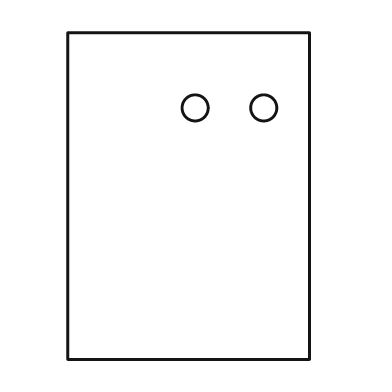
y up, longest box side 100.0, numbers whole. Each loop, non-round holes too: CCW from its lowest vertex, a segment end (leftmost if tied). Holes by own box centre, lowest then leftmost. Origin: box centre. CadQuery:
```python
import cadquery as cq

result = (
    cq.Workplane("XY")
    .moveTo(-37.0, -50.0)
    .lineTo(37.0, -50.0)
    .lineTo(37.0, 50.0)
    .lineTo(-37.0, 50.0)
    .close()
    .moveTo(2.0, 27.0)
    .circle(4.0)
    .moveTo(23.0, 27.0)
    .circle(4.0)
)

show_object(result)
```